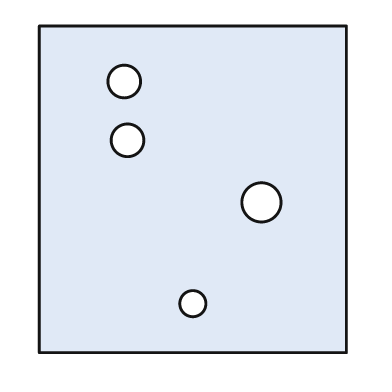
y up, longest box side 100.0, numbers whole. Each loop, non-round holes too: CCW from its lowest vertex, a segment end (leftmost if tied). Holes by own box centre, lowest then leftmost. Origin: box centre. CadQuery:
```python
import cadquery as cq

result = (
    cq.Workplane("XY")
    .moveTo(-47.0, -50.0)
    .lineTo(47.0, -50.0)
    .lineTo(47.0, 50.0)
    .lineTo(-47.0, 50.0)
    .close()
    .moveTo(0.0, -35.0)
    .circle(4.0)
    .moveTo(21.0, -4.0)
    .circle(6.0)
    .moveTo(-20.0, 15.0)
    .circle(5.0)
    .moveTo(-21.0, 33.0)
    .circle(5.0)
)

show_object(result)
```